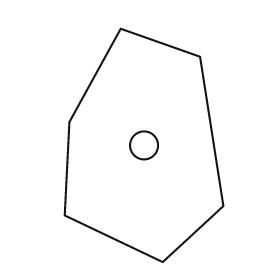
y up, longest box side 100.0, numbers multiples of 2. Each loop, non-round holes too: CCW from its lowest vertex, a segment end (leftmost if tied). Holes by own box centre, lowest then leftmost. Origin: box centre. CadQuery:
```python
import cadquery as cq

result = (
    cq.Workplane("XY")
    .moveTo(8.0, -50.0)
    .lineTo(34.0, -26.0)
    .lineTo(24.0, 38.0)
    .lineTo(-10.0, 50.0)
    .lineTo(-32.0, 10.0)
    .lineTo(-34.0, -30.0)
    .close()
    .moveTo(0.0, 0.0)
    .circle(6.0)
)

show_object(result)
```